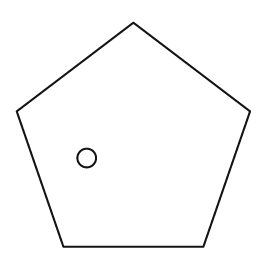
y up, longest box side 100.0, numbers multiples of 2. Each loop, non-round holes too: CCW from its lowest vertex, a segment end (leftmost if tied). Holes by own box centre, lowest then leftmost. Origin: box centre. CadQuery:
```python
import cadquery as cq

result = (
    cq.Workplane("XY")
    .moveTo(-30.0, -48.0)
    .lineTo(30.0, -48.0)
    .lineTo(50.0, 10.0)
    .lineTo(0.0, 48.0)
    .lineTo(-50.0, 10.0)
    .close()
    .moveTo(-20.0, -10.0)
    .circle(4.0)
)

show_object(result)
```